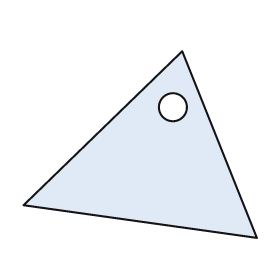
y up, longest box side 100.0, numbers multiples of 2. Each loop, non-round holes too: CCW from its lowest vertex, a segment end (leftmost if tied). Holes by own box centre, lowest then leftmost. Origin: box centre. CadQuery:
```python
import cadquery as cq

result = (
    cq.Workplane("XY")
    .moveTo(50.0, -40.0)
    .lineTo(18.0, 40.0)
    .lineTo(-50.0, -26.0)
    .close()
    .moveTo(14.0, 16.0)
    .circle(6.0)
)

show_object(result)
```